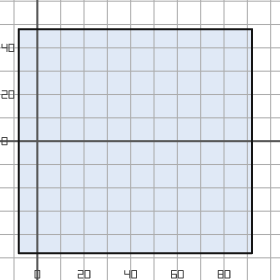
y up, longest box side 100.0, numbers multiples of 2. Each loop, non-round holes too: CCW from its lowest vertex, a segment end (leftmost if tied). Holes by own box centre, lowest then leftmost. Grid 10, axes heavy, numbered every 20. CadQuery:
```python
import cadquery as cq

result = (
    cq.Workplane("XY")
    .moveTo(-8.0, -48.0)
    .lineTo(92.0, -48.0)
    .lineTo(92.0, 48.0)
    .lineTo(-8.0, 48.0)
    .close()
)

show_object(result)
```